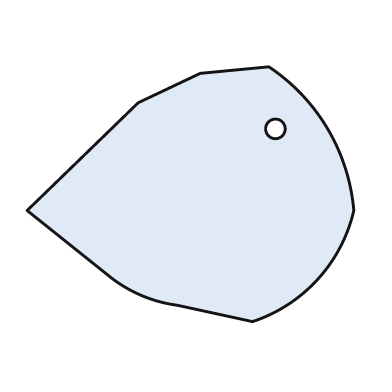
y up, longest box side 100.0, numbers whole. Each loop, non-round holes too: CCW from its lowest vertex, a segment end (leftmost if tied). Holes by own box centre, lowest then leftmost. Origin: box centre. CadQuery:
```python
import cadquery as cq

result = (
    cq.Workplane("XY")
    .moveTo(19.0, -39.0)
    .threePointArc((39.0, -26.0), (50.0, -5.0))
    .threePointArc((42.0, 20.0), (24.0, 39.0))
    .lineTo(3.0, 37.0)
    .lineTo(-16.0, 28.0)
    .lineTo(-50.0, -5.0)
    .lineTo(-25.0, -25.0)
    .threePointArc((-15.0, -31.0), (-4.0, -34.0))
    .close()
    .moveTo(26.0, 20.0)
    .circle(3.0)
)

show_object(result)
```